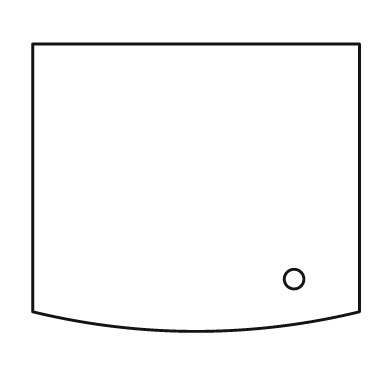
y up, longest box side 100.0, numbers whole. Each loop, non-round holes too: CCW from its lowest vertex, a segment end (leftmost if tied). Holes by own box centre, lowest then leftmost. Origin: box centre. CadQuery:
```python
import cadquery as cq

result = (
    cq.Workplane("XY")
    .moveTo(-50.0, -38.0)
    .threePointArc((0.0, -44.0), (50.0, -38.0))
    .lineTo(50.0, 44.0)
    .lineTo(-50.0, 44.0)
    .close()
    .moveTo(30.0, -28.0)
    .circle(3.0)
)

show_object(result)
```